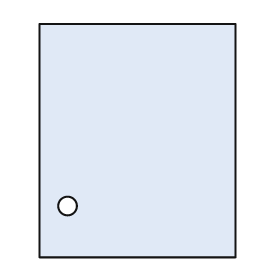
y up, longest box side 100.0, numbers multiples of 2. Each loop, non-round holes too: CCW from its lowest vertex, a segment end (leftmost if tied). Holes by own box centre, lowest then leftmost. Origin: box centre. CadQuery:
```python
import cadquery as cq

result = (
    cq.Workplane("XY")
    .moveTo(-42.0, -50.0)
    .lineTo(42.0, -50.0)
    .lineTo(42.0, 50.0)
    .lineTo(-42.0, 50.0)
    .close()
    .moveTo(-30.0, -28.0)
    .circle(4.0)
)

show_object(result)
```